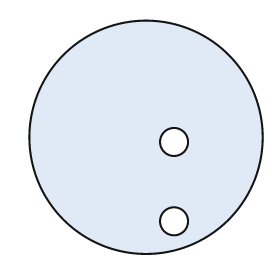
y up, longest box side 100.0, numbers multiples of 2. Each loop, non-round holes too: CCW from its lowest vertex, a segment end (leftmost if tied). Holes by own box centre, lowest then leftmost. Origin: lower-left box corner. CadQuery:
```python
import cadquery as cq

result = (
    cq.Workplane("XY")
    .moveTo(50.0, 50.0)
    .circle(50.0)
    .moveTo(62.0, 14.0)
    .circle(6.0)
    .moveTo(62.0, 48.0)
    .circle(6.0)
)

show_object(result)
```